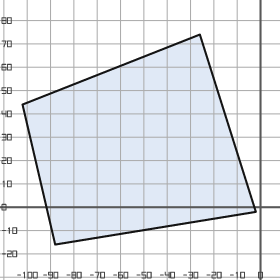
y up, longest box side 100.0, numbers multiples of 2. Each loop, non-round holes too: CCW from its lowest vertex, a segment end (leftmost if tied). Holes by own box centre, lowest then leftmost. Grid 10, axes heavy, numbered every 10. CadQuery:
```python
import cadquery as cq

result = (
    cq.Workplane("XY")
    .moveTo(-88.0, -16.0)
    .lineTo(-2.0, -2.0)
    .lineTo(-26.0, 74.0)
    .lineTo(-102.0, 44.0)
    .close()
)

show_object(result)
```